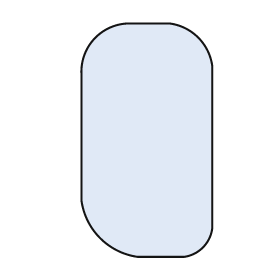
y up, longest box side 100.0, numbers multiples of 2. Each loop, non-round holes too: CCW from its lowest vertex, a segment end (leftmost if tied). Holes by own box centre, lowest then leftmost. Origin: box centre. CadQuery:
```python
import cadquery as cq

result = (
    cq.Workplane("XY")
    .moveTo(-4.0, -50.0)
    .lineTo(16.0, -50.0)
    .threePointArc((24.0, -46.0), (28.0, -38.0))
    .lineTo(28.0, 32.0)
    .threePointArc((22.0, 44.0), (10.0, 50.0))
    .lineTo(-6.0, 50.0)
    .threePointArc((-22.0, 44.0), (-28.0, 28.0))
    .lineTo(-28.0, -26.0)
    .threePointArc((-20.0, -42.0), (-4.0, -50.0))
    .close()
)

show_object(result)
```